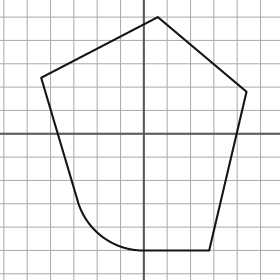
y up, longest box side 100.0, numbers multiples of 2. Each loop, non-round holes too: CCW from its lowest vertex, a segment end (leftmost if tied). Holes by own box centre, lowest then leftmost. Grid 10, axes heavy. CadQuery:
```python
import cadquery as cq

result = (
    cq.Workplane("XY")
    .moveTo(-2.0, -50.0)
    .lineTo(28.0, -50.0)
    .lineTo(44.0, 18.0)
    .lineTo(6.0, 50.0)
    .lineTo(-44.0, 24.0)
    .lineTo(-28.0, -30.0)
    .threePointArc((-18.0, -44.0), (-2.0, -50.0))
    .close()
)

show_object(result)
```